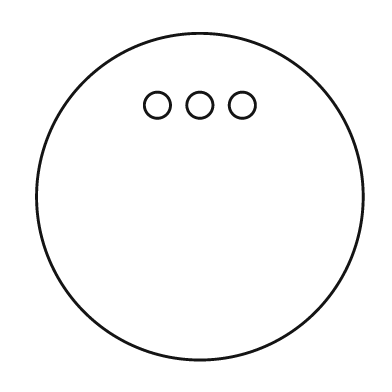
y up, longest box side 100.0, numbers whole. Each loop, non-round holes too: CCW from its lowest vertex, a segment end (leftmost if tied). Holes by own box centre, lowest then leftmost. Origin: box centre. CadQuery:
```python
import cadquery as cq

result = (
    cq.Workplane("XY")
    .moveTo(0.0, 0.0)
    .circle(50.0)
    .moveTo(-13.0, 28.0)
    .circle(4.0)
    .moveTo(0.0, 28.0)
    .circle(4.0)
    .moveTo(13.0, 28.0)
    .circle(4.0)
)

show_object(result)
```